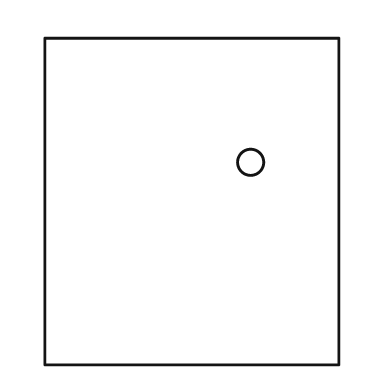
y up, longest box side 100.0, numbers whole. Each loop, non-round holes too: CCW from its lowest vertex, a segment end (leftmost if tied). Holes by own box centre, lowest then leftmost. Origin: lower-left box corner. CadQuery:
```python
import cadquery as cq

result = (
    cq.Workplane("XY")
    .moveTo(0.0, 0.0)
    .lineTo(90.0, 0.0)
    .lineTo(90.0, 100.0)
    .lineTo(0.0, 100.0)
    .close()
    .moveTo(63.0, 62.0)
    .circle(4.0)
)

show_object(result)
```